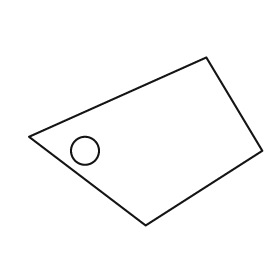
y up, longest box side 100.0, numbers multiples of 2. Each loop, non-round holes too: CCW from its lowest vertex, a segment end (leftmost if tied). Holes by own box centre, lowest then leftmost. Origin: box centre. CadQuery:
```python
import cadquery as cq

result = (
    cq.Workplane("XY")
    .moveTo(0.0, -36.0)
    .lineTo(50.0, -4.0)
    .lineTo(26.0, 36.0)
    .lineTo(-50.0, 2.0)
    .close()
    .moveTo(-26.0, -4.0)
    .circle(6.0)
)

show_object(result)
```